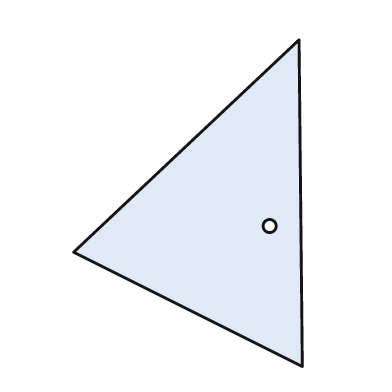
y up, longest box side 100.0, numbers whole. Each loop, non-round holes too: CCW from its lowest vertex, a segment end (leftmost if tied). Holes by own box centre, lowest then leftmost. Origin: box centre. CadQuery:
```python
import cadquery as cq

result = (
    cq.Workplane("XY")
    .moveTo(35.0, -50.0)
    .lineTo(34.0, 50.0)
    .lineTo(-35.0, -15.0)
    .close()
    .moveTo(25.0, -7.0)
    .circle(2.0)
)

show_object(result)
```